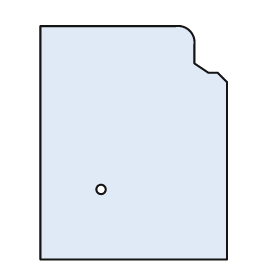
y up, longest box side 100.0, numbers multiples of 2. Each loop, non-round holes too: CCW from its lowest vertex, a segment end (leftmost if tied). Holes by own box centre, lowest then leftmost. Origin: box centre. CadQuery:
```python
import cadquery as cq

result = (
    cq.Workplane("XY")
    .moveTo(-40.0, -50.0)
    .lineTo(40.0, -50.0)
    .lineTo(40.0, 26.0)
    .lineTo(36.0, 30.0)
    .lineTo(32.0, 30.0)
    .lineTo(26.0, 34.0)
    .lineTo(26.0, 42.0)
    .threePointArc((24.0, 48.0), (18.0, 50.0))
    .lineTo(-40.0, 50.0)
    .close()
    .moveTo(-14.0, -20.0)
    .circle(2.0)
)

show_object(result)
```